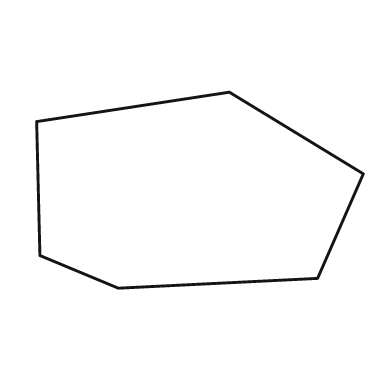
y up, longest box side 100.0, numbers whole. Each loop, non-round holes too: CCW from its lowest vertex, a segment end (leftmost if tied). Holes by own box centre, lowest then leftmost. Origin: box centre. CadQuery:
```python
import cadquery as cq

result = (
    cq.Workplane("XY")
    .moveTo(-25.0, -30.0)
    .lineTo(36.0, -27.0)
    .lineTo(50.0, 5.0)
    .lineTo(9.0, 30.0)
    .lineTo(-50.0, 21.0)
    .lineTo(-49.0, -20.0)
    .close()
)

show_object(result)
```